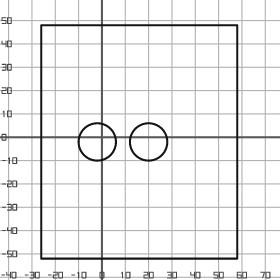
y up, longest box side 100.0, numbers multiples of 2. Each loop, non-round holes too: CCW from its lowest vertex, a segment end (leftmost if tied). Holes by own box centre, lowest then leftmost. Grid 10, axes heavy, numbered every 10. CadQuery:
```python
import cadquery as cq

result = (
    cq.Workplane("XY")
    .moveTo(-26.0, -52.0)
    .lineTo(58.0, -52.0)
    .lineTo(58.0, 48.0)
    .lineTo(-26.0, 48.0)
    .close()
    .moveTo(-2.0, -2.0)
    .circle(8.0)
    .moveTo(20.0, -2.0)
    .circle(8.0)
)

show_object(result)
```